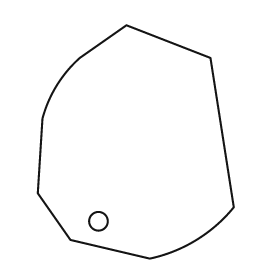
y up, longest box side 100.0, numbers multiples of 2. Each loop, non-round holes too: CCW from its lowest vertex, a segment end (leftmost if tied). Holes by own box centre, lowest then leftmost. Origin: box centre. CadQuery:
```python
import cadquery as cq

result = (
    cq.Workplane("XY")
    .moveTo(6.0, -50.0)
    .threePointArc((26.0, -42.0), (42.0, -28.0))
    .lineTo(32.0, 36.0)
    .lineTo(-4.0, 50.0)
    .lineTo(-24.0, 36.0)
    .threePointArc((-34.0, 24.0), (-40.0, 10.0))
    .lineTo(-42.0, -22.0)
    .lineTo(-28.0, -42.0)
    .close()
    .moveTo(-16.0, -34.0)
    .circle(4.0)
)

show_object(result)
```